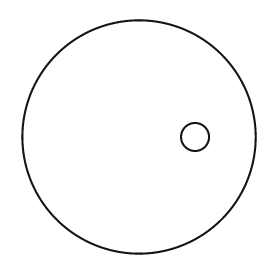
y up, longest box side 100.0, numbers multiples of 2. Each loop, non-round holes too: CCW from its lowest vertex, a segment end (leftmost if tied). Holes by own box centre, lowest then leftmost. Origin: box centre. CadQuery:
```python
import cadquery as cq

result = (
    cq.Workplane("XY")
    .moveTo(0.0, 0.0)
    .circle(50.0)
    .moveTo(24.0, 0.0)
    .circle(6.0)
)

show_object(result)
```